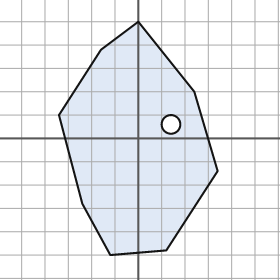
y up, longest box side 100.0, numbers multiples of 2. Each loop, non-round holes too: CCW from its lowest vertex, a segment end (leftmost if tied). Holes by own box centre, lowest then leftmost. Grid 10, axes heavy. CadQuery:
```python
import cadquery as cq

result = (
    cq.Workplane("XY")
    .moveTo(-12.0, -50.0)
    .lineTo(12.0, -48.0)
    .lineTo(34.0, -14.0)
    .lineTo(24.0, 20.0)
    .lineTo(0.0, 50.0)
    .lineTo(-16.0, 38.0)
    .lineTo(-34.0, 10.0)
    .lineTo(-24.0, -28.0)
    .close()
    .moveTo(14.0, 6.0)
    .circle(4.0)
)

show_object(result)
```